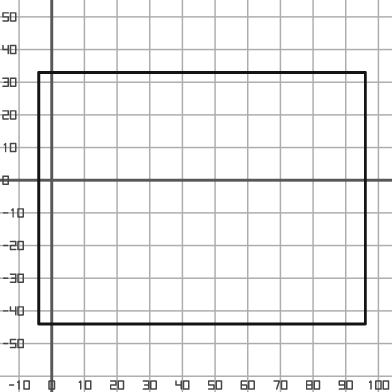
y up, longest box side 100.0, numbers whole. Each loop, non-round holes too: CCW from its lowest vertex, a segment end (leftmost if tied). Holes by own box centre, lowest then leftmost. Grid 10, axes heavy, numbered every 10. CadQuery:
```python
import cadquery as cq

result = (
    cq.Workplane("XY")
    .moveTo(-4.0, -44.0)
    .lineTo(96.0, -44.0)
    .lineTo(96.0, 33.0)
    .lineTo(-4.0, 33.0)
    .close()
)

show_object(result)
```